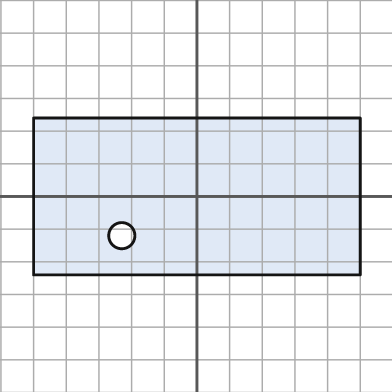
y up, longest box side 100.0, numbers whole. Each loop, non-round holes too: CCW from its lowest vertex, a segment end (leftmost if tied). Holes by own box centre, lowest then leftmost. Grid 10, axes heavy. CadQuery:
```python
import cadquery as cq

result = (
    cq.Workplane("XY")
    .moveTo(-50.0, -24.0)
    .lineTo(50.0, -24.0)
    .lineTo(50.0, 24.0)
    .lineTo(-50.0, 24.0)
    .close()
    .moveTo(-23.0, -12.0)
    .circle(4.0)
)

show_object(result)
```